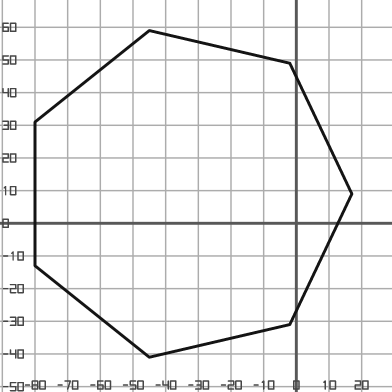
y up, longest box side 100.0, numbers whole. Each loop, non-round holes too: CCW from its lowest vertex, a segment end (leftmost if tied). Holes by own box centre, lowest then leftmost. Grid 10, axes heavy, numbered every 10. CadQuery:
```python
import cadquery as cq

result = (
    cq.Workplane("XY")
    .moveTo(-45.0, -41.0)
    .lineTo(-2.0, -31.0)
    .lineTo(17.0, 9.0)
    .lineTo(-2.0, 49.0)
    .lineTo(-45.0, 59.0)
    .lineTo(-80.0, 31.0)
    .lineTo(-80.0, -13.0)
    .close()
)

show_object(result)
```